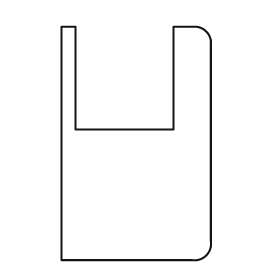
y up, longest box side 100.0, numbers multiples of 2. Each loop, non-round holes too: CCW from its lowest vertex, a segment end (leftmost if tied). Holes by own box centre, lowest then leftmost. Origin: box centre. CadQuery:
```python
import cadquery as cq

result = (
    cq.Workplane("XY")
    .moveTo(-32.0, -50.0)
    .lineTo(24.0, -50.0)
    .threePointArc((30.0, -48.0), (32.0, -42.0))
    .lineTo(32.0, 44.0)
    .threePointArc((30.0, 48.0), (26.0, 50.0))
    .lineTo(16.0, 50.0)
    .lineTo(16.0, 6.0)
    .lineTo(-26.0, 6.0)
    .lineTo(-26.0, 50.0)
    .lineTo(-32.0, 50.0)
    .close()
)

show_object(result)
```